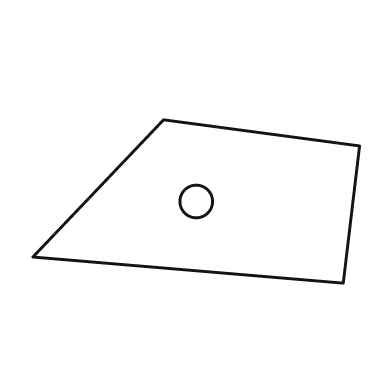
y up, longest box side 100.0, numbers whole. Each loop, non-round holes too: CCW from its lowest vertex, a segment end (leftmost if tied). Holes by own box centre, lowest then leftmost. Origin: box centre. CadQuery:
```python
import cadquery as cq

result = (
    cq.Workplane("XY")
    .moveTo(45.0, -25.0)
    .lineTo(50.0, 17.0)
    .lineTo(-10.0, 25.0)
    .lineTo(-50.0, -17.0)
    .close()
    .moveTo(0.0, 0.0)
    .circle(5.0)
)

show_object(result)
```